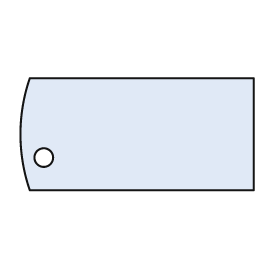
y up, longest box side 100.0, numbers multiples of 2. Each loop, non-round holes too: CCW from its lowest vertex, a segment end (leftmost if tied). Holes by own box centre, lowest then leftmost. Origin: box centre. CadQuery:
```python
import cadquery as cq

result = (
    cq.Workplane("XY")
    .moveTo(-46.0, -24.0)
    .lineTo(50.0, -24.0)
    .lineTo(50.0, 24.0)
    .lineTo(-46.0, 24.0)
    .threePointArc((-50.0, 0.0), (-46.0, -24.0))
    .close()
    .moveTo(-40.0, -10.0)
    .circle(4.0)
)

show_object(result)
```